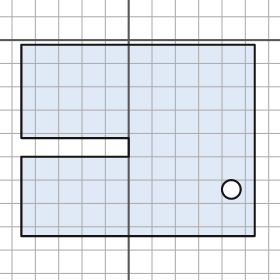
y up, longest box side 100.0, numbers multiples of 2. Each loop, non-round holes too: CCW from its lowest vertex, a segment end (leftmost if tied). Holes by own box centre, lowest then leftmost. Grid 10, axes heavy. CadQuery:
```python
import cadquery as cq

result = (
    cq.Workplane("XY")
    .moveTo(-46.0, -84.0)
    .lineTo(54.0, -84.0)
    .lineTo(54.0, -2.0)
    .lineTo(-46.0, -2.0)
    .lineTo(-46.0, -42.0)
    .lineTo(0.0, -42.0)
    .lineTo(0.0, -50.0)
    .lineTo(-46.0, -50.0)
    .close()
    .moveTo(44.0, -64.0)
    .circle(4.0)
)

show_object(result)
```